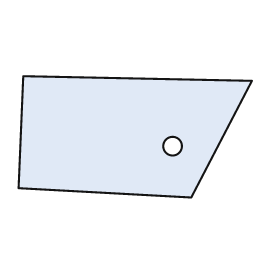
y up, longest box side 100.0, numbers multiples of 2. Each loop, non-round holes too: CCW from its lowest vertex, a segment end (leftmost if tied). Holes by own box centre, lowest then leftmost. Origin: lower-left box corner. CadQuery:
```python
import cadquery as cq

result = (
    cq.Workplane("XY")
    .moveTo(74.0, 0.0)
    .lineTo(100.0, 50.0)
    .lineTo(2.0, 52.0)
    .lineTo(0.0, 4.0)
    .close()
    .moveTo(66.0, 22.0)
    .circle(4.0)
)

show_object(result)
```